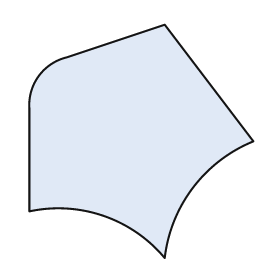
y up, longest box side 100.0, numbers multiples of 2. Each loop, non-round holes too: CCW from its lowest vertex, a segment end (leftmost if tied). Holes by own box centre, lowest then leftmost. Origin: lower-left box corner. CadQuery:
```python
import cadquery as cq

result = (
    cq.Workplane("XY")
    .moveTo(58.0, 0.0)
    .threePointArc((70.0, 30.0), (96.0, 50.0))
    .lineTo(58.0, 100.0)
    .lineTo(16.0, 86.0)
    .threePointArc((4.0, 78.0), (0.0, 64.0))
    .lineTo(0.0, 20.0)
    .threePointArc((32.0, 18.0), (58.0, 0.0))
    .close()
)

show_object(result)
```